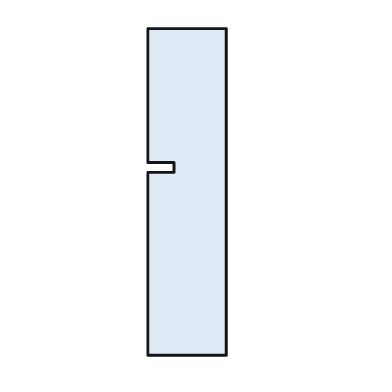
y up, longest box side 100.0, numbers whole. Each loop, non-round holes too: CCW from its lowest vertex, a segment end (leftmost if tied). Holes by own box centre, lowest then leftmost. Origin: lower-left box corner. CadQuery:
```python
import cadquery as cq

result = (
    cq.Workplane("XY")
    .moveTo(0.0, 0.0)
    .lineTo(24.0, 0.0)
    .lineTo(24.0, 100.0)
    .lineTo(0.0, 100.0)
    .lineTo(0.0, 59.0)
    .lineTo(8.0, 59.0)
    .lineTo(8.0, 56.0)
    .lineTo(0.0, 56.0)
    .close()
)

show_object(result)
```